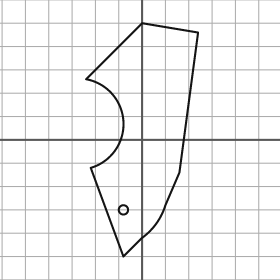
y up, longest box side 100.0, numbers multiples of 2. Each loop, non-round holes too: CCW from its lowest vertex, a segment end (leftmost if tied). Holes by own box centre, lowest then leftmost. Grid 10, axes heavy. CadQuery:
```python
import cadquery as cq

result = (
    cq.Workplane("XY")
    .moveTo(-8.0, -50.0)
    .lineTo(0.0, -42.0)
    .threePointArc((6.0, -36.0), (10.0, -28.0))
    .lineTo(16.0, -14.0)
    .lineTo(24.0, 46.0)
    .lineTo(0.0, 50.0)
    .lineTo(-24.0, 26.0)
    .threePointArc((-8.0, 8.0), (-22.0, -12.0))
    .close()
    .moveTo(-8.0, -30.0)
    .circle(2.0)
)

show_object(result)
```